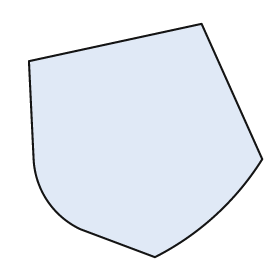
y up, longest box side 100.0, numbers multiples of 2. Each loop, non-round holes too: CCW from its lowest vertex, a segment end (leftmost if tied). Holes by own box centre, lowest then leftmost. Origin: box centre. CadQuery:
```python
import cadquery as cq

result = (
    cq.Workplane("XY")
    .moveTo(4.0, -50.0)
    .threePointArc((30.0, -32.0), (50.0, -8.0))
    .lineTo(24.0, 50.0)
    .lineTo(-50.0, 34.0)
    .lineTo(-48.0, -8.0)
    .threePointArc((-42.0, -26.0), (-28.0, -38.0))
    .close()
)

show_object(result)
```